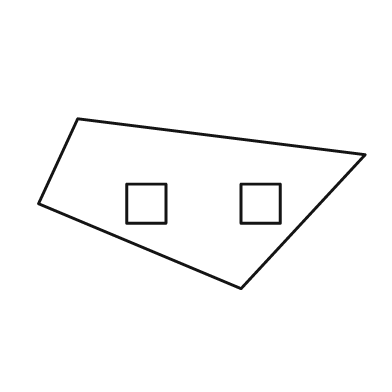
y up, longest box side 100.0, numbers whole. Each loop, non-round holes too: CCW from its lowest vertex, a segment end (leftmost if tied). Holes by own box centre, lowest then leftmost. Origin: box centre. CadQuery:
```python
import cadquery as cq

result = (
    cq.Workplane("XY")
    .moveTo(12.0, -26.0)
    .lineTo(50.0, 15.0)
    .lineTo(-38.0, 26.0)
    .lineTo(-50.0, 0.0)
    .close()
    .moveTo(-23.0, -6.0)
    .lineTo(-11.0, -6.0)
    .lineTo(-11.0, 6.0)
    .lineTo(-23.0, 6.0)
    .close()
    .moveTo(12.0, -6.0)
    .lineTo(24.0, -6.0)
    .lineTo(24.0, 6.0)
    .lineTo(12.0, 6.0)
    .close()
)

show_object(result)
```